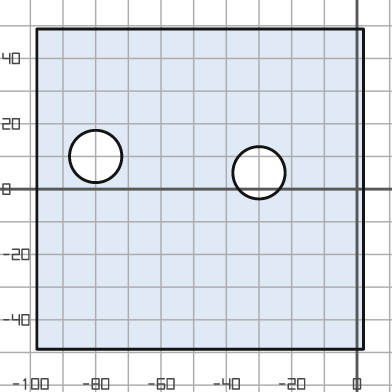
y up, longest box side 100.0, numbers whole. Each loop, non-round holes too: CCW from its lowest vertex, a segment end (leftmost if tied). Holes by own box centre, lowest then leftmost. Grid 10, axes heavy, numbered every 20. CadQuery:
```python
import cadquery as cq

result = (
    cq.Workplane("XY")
    .moveTo(-98.0, -49.0)
    .lineTo(2.0, -49.0)
    .lineTo(2.0, 49.0)
    .lineTo(-98.0, 49.0)
    .close()
    .moveTo(-30.0, 5.0)
    .circle(8.0)
    .moveTo(-80.0, 10.0)
    .circle(8.0)
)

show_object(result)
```